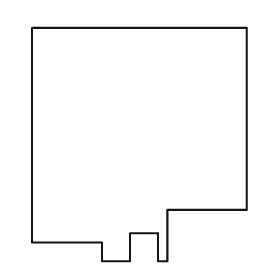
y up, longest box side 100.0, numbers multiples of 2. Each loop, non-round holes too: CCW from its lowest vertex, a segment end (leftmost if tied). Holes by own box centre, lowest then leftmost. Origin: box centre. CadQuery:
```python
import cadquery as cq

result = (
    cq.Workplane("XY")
    .moveTo(-16.0, -50.0)
    .lineTo(-4.0, -50.0)
    .lineTo(-4.0, -38.0)
    .lineTo(8.0, -38.0)
    .lineTo(8.0, -50.0)
    .lineTo(12.0, -50.0)
    .lineTo(12.0, -28.0)
    .lineTo(46.0, -28.0)
    .lineTo(46.0, 50.0)
    .lineTo(-46.0, 50.0)
    .lineTo(-46.0, -42.0)
    .lineTo(-16.0, -42.0)
    .close()
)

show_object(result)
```